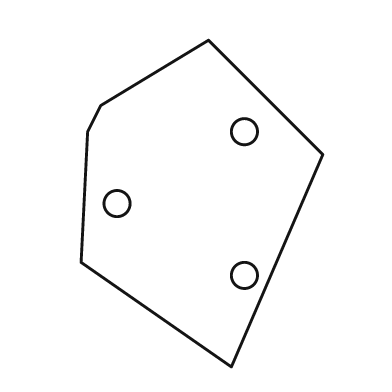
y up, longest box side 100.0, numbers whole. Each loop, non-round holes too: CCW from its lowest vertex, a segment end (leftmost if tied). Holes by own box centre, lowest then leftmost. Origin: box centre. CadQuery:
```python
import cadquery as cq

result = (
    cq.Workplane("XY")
    .moveTo(9.0, -50.0)
    .lineTo(37.0, 15.0)
    .lineTo(2.0, 50.0)
    .lineTo(-31.0, 30.0)
    .lineTo(-35.0, 22.0)
    .lineTo(-37.0, -18.0)
    .close()
    .moveTo(13.0, -22.0)
    .circle(4.0)
    .moveTo(-26.0, 0.0)
    .circle(4.0)
    .moveTo(13.0, 22.0)
    .circle(4.0)
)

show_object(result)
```